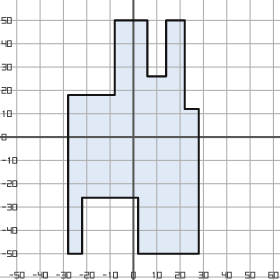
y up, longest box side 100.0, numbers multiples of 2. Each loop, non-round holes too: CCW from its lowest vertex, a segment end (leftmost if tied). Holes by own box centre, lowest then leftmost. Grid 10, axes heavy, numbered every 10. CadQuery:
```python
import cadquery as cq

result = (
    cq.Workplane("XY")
    .moveTo(-28.0, -50.0)
    .lineTo(-22.0, -50.0)
    .lineTo(-22.0, -26.0)
    .lineTo(2.0, -26.0)
    .lineTo(2.0, -50.0)
    .lineTo(28.0, -50.0)
    .lineTo(28.0, 12.0)
    .lineTo(22.0, 12.0)
    .lineTo(22.0, 50.0)
    .lineTo(14.0, 50.0)
    .lineTo(14.0, 26.0)
    .lineTo(6.0, 26.0)
    .lineTo(6.0, 50.0)
    .lineTo(-8.0, 50.0)
    .lineTo(-8.0, 18.0)
    .lineTo(-28.0, 18.0)
    .close()
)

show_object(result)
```